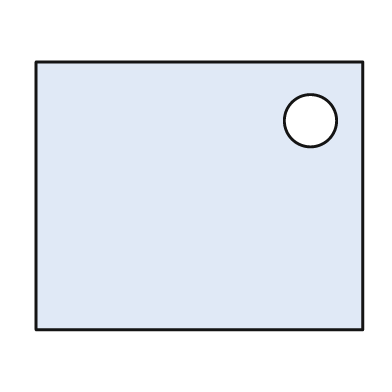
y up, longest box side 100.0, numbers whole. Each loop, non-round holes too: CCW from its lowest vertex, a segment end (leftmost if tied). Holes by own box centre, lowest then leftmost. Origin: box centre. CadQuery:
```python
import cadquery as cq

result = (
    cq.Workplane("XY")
    .moveTo(-50.0, -41.0)
    .lineTo(50.0, -41.0)
    .lineTo(50.0, 41.0)
    .lineTo(-50.0, 41.0)
    .close()
    .moveTo(34.0, 23.0)
    .circle(8.0)
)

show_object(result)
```